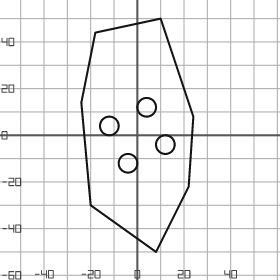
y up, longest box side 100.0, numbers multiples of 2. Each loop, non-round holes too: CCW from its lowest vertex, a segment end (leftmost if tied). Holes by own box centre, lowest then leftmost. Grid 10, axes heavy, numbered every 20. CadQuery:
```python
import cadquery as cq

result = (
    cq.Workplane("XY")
    .moveTo(8.0, -50.0)
    .lineTo(22.0, -22.0)
    .lineTo(24.0, 8.0)
    .lineTo(10.0, 50.0)
    .lineTo(-18.0, 44.0)
    .lineTo(-24.0, 14.0)
    .lineTo(-20.0, -30.0)
    .close()
    .moveTo(-4.0, -12.0)
    .circle(4.0)
    .moveTo(12.0, -4.0)
    .circle(4.0)
    .moveTo(-12.0, 4.0)
    .circle(4.0)
    .moveTo(4.0, 12.0)
    .circle(4.0)
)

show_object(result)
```